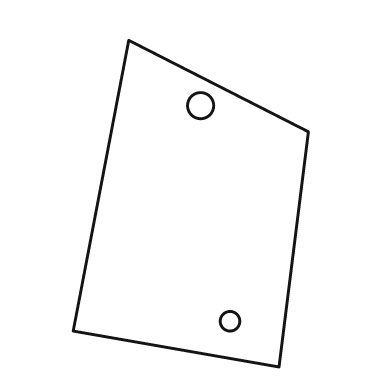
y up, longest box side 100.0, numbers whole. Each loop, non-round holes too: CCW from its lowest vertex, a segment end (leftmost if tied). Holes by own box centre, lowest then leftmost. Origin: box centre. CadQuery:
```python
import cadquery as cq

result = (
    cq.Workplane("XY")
    .moveTo(27.0, -50.0)
    .lineTo(36.0, 22.0)
    .lineTo(-19.0, 50.0)
    .lineTo(-36.0, -39.0)
    .close()
    .moveTo(12.0, -36.0)
    .circle(3.0)
    .moveTo(3.0, 30.0)
    .circle(4.0)
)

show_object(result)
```